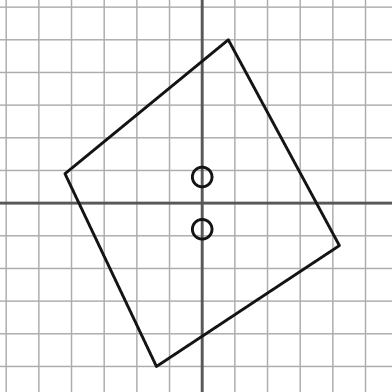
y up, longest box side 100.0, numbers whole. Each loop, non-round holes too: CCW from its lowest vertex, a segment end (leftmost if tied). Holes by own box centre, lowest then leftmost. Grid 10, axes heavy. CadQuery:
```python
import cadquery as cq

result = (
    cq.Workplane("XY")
    .moveTo(-14.0, -50.0)
    .lineTo(42.0, -13.0)
    .lineTo(8.0, 50.0)
    .lineTo(-42.0, 9.0)
    .close()
    .moveTo(0.0, -8.0)
    .circle(3.0)
    .moveTo(0.0, 8.0)
    .circle(3.0)
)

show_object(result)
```